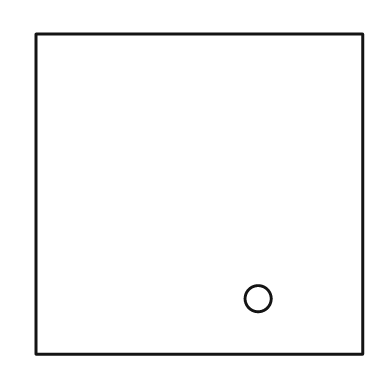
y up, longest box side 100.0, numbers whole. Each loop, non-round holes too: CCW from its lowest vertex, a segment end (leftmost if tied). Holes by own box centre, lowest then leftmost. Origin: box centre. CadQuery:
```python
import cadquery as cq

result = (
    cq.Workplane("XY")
    .moveTo(-50.0, -49.0)
    .lineTo(50.0, -49.0)
    .lineTo(50.0, 49.0)
    .lineTo(-50.0, 49.0)
    .close()
    .moveTo(18.0, -32.0)
    .circle(4.0)
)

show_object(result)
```